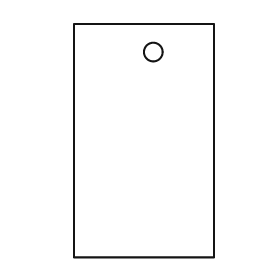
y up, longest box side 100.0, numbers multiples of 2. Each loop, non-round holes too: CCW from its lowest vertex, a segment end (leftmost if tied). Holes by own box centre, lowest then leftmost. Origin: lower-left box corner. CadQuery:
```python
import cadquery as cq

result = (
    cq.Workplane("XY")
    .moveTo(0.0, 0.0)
    .lineTo(60.0, 0.0)
    .lineTo(60.0, 100.0)
    .lineTo(0.0, 100.0)
    .close()
    .moveTo(34.0, 88.0)
    .circle(4.0)
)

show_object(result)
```